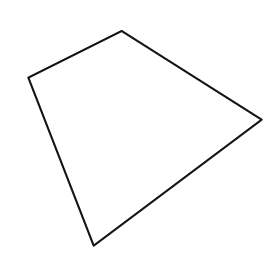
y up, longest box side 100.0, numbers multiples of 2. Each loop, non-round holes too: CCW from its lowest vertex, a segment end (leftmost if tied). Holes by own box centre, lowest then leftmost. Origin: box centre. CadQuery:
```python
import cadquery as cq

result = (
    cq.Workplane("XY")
    .moveTo(-22.0, -46.0)
    .lineTo(50.0, 8.0)
    .lineTo(-10.0, 46.0)
    .lineTo(-50.0, 26.0)
    .close()
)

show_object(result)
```